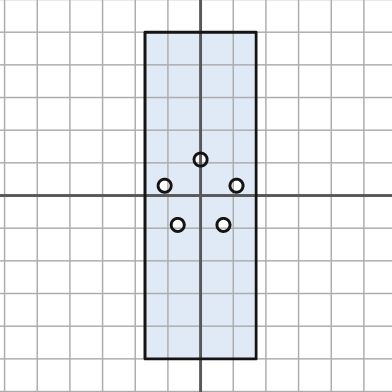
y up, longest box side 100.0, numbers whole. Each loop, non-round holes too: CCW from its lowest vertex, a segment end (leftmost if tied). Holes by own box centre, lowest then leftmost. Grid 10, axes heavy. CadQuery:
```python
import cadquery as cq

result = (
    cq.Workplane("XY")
    .moveTo(-17.0, -50.0)
    .lineTo(17.0, -50.0)
    .lineTo(17.0, 50.0)
    .lineTo(-17.0, 50.0)
    .close()
    .moveTo(-7.0, -9.0)
    .circle(2.0)
    .moveTo(7.0, -9.0)
    .circle(2.0)
    .moveTo(-11.0, 3.0)
    .circle(2.0)
    .moveTo(11.0, 3.0)
    .circle(2.0)
    .moveTo(0.0, 11.0)
    .circle(2.0)
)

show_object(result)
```